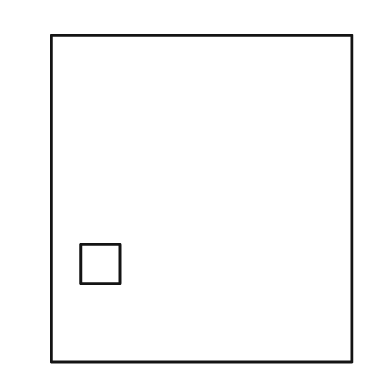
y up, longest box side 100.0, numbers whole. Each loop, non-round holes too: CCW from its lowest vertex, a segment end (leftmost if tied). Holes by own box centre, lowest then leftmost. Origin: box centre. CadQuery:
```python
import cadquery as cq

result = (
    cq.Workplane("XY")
    .moveTo(-46.0, -50.0)
    .lineTo(46.0, -50.0)
    .lineTo(46.0, 50.0)
    .lineTo(-46.0, 50.0)
    .close()
    .moveTo(-37.0, -26.0)
    .lineTo(-25.0, -26.0)
    .lineTo(-25.0, -14.0)
    .lineTo(-37.0, -14.0)
    .close()
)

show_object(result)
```